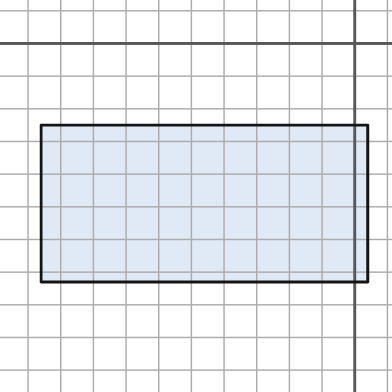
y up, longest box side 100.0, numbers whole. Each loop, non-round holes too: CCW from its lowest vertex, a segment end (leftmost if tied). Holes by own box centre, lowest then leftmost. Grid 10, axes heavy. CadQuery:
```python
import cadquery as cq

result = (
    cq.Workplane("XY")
    .moveTo(-96.0, -73.0)
    .lineTo(4.0, -73.0)
    .lineTo(4.0, -25.0)
    .lineTo(-96.0, -25.0)
    .close()
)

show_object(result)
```